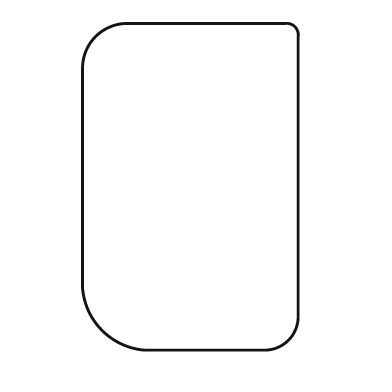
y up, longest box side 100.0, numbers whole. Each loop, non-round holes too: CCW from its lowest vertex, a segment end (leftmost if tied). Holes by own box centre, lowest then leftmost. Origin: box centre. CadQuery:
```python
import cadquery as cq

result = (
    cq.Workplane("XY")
    .moveTo(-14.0, -50.0)
    .lineTo(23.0, -50.0)
    .threePointArc((30.0, -47.0), (33.0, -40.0))
    .lineTo(33.0, 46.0)
    .threePointArc((32.0, 49.0), (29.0, 50.0))
    .lineTo(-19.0, 50.0)
    .threePointArc((-29.0, 46.0), (-33.0, 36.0))
    .lineTo(-33.0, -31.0)
    .threePointArc((-27.0, -44.0), (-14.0, -50.0))
    .close()
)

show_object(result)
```